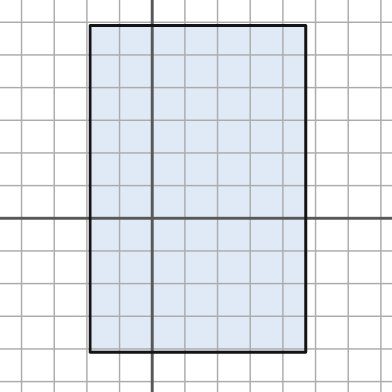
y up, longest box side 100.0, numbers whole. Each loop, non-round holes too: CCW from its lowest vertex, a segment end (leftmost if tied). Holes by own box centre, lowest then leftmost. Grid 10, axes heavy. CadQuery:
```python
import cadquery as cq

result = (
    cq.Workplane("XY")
    .moveTo(-19.0, -41.0)
    .lineTo(47.0, -41.0)
    .lineTo(47.0, 59.0)
    .lineTo(-19.0, 59.0)
    .close()
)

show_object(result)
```